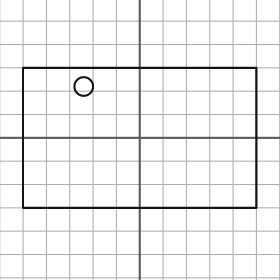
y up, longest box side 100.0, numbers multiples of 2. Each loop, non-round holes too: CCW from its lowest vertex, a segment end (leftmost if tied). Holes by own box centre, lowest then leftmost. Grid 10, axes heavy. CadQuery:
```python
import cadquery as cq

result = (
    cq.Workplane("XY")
    .moveTo(-50.0, -30.0)
    .lineTo(50.0, -30.0)
    .lineTo(50.0, 30.0)
    .lineTo(-50.0, 30.0)
    .close()
    .moveTo(-24.0, 22.0)
    .circle(4.0)
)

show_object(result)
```